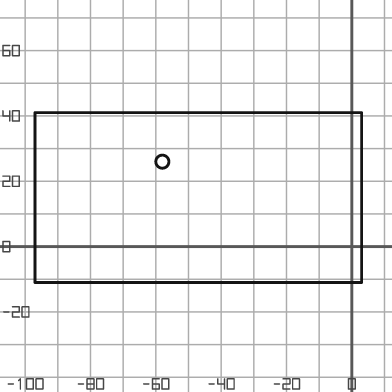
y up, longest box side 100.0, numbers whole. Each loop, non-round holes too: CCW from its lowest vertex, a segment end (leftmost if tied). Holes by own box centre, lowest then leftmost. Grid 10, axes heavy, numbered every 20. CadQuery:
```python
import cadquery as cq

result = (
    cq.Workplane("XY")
    .moveTo(-97.0, -11.0)
    .lineTo(3.0, -11.0)
    .lineTo(3.0, 41.0)
    .lineTo(-97.0, 41.0)
    .close()
    .moveTo(-58.0, 26.0)
    .circle(2.0)
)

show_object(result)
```